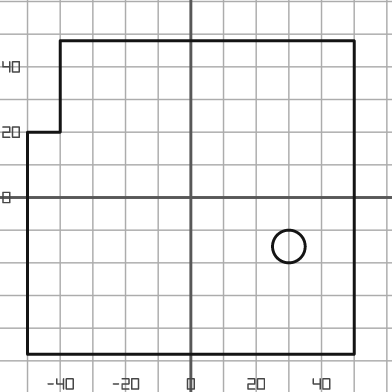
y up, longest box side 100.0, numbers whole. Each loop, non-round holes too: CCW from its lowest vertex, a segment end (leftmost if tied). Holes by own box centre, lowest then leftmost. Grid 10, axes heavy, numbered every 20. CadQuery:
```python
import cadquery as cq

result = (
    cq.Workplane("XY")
    .moveTo(-50.0, -48.0)
    .lineTo(50.0, -48.0)
    .lineTo(50.0, 48.0)
    .lineTo(-40.0, 48.0)
    .lineTo(-40.0, 20.0)
    .lineTo(-50.0, 20.0)
    .close()
    .moveTo(30.0, -15.0)
    .circle(5.0)
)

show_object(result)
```